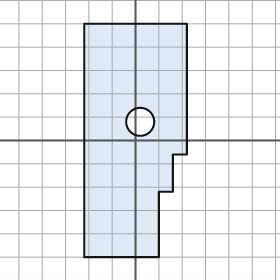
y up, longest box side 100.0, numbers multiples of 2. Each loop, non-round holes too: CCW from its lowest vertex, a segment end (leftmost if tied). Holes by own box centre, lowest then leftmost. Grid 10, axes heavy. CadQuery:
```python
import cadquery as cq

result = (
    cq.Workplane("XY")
    .moveTo(-22.0, -50.0)
    .lineTo(10.0, -50.0)
    .lineTo(10.0, -22.0)
    .lineTo(16.0, -22.0)
    .lineTo(16.0, -6.0)
    .lineTo(22.0, -6.0)
    .lineTo(22.0, 50.0)
    .lineTo(-22.0, 50.0)
    .close()
    .moveTo(2.0, 8.0)
    .circle(6.0)
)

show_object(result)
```